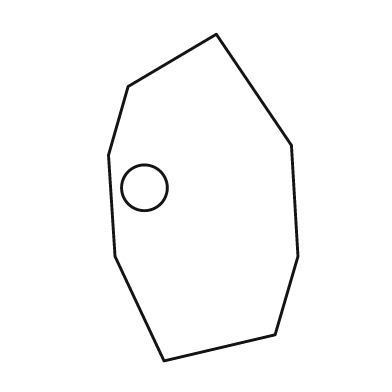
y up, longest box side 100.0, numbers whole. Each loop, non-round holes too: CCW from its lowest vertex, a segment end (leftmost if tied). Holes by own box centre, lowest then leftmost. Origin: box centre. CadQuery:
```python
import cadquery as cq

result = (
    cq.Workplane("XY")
    .moveTo(-12.0, -50.0)
    .lineTo(22.0, -42.0)
    .lineTo(29.0, -18.0)
    .lineTo(27.0, 16.0)
    .lineTo(4.0, 50.0)
    .lineTo(-23.0, 34.0)
    .lineTo(-29.0, 13.0)
    .lineTo(-27.0, -18.0)
    .close()
    .moveTo(-18.0, 3.0)
    .circle(7.0)
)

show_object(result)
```